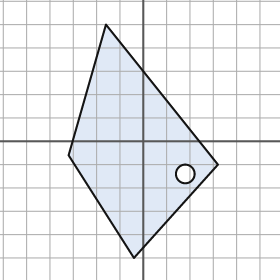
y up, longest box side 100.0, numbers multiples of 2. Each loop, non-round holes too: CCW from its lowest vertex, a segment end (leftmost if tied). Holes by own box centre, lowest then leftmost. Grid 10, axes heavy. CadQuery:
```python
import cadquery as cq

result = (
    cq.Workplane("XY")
    .moveTo(-4.0, -50.0)
    .lineTo(32.0, -10.0)
    .lineTo(-16.0, 50.0)
    .lineTo(-32.0, -6.0)
    .close()
    .moveTo(18.0, -14.0)
    .circle(4.0)
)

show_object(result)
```